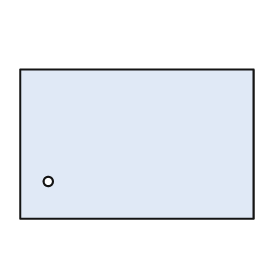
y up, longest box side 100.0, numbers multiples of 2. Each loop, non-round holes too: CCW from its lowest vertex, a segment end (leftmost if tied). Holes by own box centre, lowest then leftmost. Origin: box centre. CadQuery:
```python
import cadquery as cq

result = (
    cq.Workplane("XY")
    .moveTo(-50.0, -32.0)
    .lineTo(50.0, -32.0)
    .lineTo(50.0, 32.0)
    .lineTo(-50.0, 32.0)
    .close()
    .moveTo(-38.0, -16.0)
    .circle(2.0)
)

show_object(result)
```